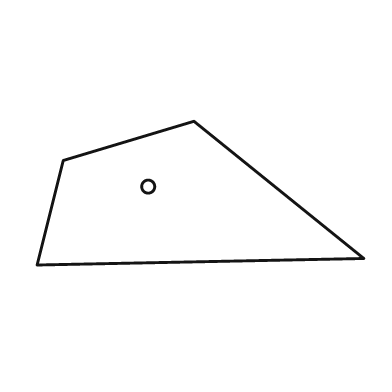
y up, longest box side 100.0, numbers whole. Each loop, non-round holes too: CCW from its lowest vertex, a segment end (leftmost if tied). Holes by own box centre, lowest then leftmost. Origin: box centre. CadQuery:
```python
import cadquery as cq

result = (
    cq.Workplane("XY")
    .moveTo(-50.0, -22.0)
    .lineTo(50.0, -20.0)
    .lineTo(-2.0, 22.0)
    .lineTo(-42.0, 10.0)
    .close()
    .moveTo(-16.0, 2.0)
    .circle(2.0)
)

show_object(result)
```